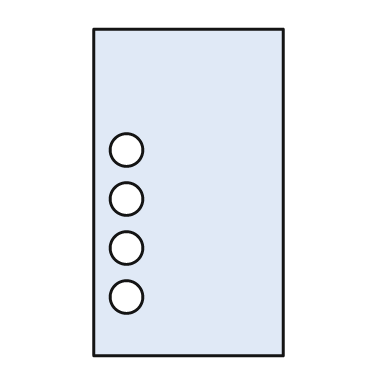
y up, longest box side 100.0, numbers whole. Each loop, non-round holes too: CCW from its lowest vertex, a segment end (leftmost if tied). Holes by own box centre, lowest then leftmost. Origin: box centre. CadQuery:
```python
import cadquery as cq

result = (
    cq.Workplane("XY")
    .moveTo(-29.0, -50.0)
    .lineTo(29.0, -50.0)
    .lineTo(29.0, 50.0)
    .lineTo(-29.0, 50.0)
    .close()
    .moveTo(-19.0, -32.0)
    .circle(5.0)
    .moveTo(-19.0, -17.0)
    .circle(5.0)
    .moveTo(-19.0, -2.0)
    .circle(5.0)
    .moveTo(-19.0, 13.0)
    .circle(5.0)
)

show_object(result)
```